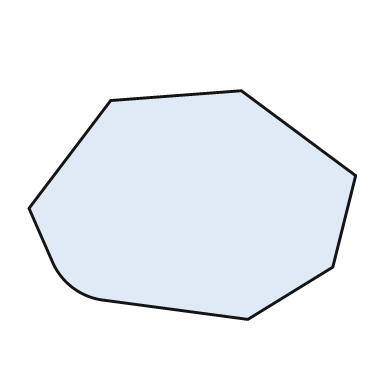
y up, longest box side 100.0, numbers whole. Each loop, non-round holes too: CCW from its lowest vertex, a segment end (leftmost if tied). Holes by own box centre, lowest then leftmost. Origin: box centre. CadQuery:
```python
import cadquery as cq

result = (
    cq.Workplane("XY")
    .moveTo(17.0, -35.0)
    .lineTo(43.0, -19.0)
    .lineTo(50.0, 9.0)
    .lineTo(15.0, 35.0)
    .lineTo(-25.0, 32.0)
    .lineTo(-50.0, -1.0)
    .lineTo(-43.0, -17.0)
    .threePointArc((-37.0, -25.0), (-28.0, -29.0))
    .close()
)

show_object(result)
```